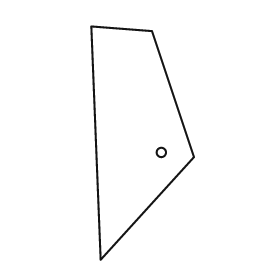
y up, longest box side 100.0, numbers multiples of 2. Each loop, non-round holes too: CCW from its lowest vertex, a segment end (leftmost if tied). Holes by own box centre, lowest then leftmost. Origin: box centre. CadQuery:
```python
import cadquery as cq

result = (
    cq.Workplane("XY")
    .moveTo(-18.0, -50.0)
    .lineTo(22.0, -6.0)
    .lineTo(4.0, 48.0)
    .lineTo(-22.0, 50.0)
    .close()
    .moveTo(8.0, -4.0)
    .circle(2.0)
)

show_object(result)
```